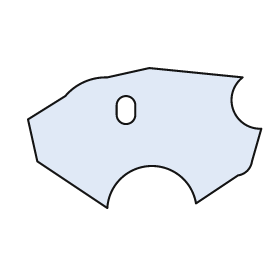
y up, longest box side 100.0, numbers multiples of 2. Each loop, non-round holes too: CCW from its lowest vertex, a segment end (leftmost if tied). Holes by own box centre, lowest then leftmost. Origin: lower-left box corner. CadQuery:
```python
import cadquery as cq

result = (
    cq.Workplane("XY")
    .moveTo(34.0, 0.0)
    .threePointArc((52.0, 18.0), (72.0, 2.0))
    .lineTo(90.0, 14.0)
    .threePointArc((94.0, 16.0), (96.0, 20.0))
    .lineTo(100.0, 34.0)
    .threePointArc((88.0, 42.0), (92.0, 56.0))
    .lineTo(52.0, 60.0)
    .lineTo(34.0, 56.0)
    .threePointArc((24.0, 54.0), (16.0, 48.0))
    .lineTo(0.0, 38.0)
    .lineTo(4.0, 20.0)
    .close()
    .moveTo(38.0, 40.0)
    .threePointArc((42.0, 36.0), (46.0, 40.0))
    .lineTo(46.0, 44.0)
    .threePointArc((42.0, 48.0), (38.0, 44.0))
    .close()
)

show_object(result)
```